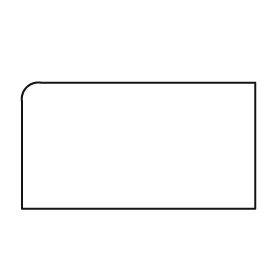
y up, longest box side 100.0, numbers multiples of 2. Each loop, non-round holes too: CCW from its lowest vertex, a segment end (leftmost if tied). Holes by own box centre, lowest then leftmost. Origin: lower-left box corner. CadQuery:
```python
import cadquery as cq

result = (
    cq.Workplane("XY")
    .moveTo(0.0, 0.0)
    .lineTo(100.0, 0.0)
    .lineTo(100.0, 54.0)
    .lineTo(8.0, 54.0)
    .threePointArc((2.0, 52.0), (0.0, 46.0))
    .close()
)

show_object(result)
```